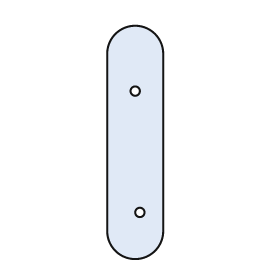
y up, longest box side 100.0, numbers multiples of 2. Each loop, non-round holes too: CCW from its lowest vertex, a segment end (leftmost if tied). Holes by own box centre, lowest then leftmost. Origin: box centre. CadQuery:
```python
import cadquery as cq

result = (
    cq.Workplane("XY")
    .moveTo(-12.0, -38.0)
    .threePointArc((0.0, -50.0), (12.0, -38.0))
    .lineTo(12.0, 38.0)
    .threePointArc((0.0, 50.0), (-12.0, 38.0))
    .close()
    .moveTo(2.0, -30.0)
    .circle(2.0)
    .moveTo(0.0, 22.0)
    .circle(2.0)
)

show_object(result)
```